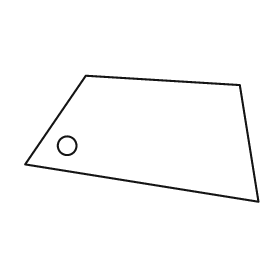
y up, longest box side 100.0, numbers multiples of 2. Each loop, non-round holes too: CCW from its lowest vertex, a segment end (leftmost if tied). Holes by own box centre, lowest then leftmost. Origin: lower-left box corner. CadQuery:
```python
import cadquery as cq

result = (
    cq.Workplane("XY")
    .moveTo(100.0, 0.0)
    .lineTo(92.0, 50.0)
    .lineTo(26.0, 54.0)
    .lineTo(0.0, 16.0)
    .close()
    .moveTo(18.0, 24.0)
    .circle(4.0)
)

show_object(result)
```